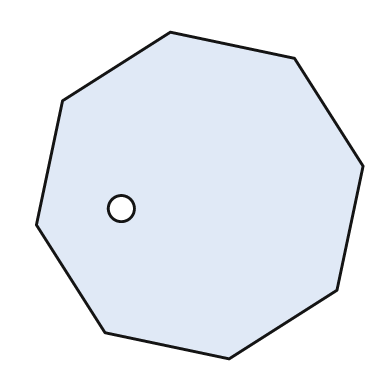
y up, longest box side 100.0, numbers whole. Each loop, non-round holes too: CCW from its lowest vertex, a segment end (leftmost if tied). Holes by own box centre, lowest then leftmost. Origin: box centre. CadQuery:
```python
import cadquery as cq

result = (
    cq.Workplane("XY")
    .moveTo(9.0, -50.0)
    .lineTo(42.0, -29.0)
    .lineTo(50.0, 9.0)
    .lineTo(29.0, 42.0)
    .lineTo(-9.0, 50.0)
    .lineTo(-42.0, 29.0)
    .lineTo(-50.0, -9.0)
    .lineTo(-29.0, -42.0)
    .close()
    .moveTo(-24.0, -4.0)
    .circle(4.0)
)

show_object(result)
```